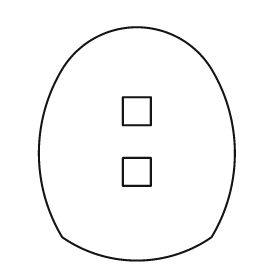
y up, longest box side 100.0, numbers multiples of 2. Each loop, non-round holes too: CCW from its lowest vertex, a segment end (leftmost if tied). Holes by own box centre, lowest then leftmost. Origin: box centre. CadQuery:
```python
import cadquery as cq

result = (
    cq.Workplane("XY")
    .moveTo(-32.0, -40.0)
    .threePointArc((0.0, -50.0), (32.0, -40.0))
    .threePointArc((42.0, -4.0), (32.0, 32.0))
    .threePointArc((0.0, 50.0), (-32.0, 32.0))
    .threePointArc((-42.0, -4.0), (-32.0, -40.0))
    .close()
    .moveTo(-6.0, -18.0)
    .lineTo(6.0, -18.0)
    .lineTo(6.0, -6.0)
    .lineTo(-6.0, -6.0)
    .close()
    .moveTo(-6.0, 8.0)
    .lineTo(6.0, 8.0)
    .lineTo(6.0, 20.0)
    .lineTo(-6.0, 20.0)
    .close()
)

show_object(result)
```